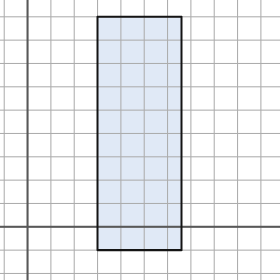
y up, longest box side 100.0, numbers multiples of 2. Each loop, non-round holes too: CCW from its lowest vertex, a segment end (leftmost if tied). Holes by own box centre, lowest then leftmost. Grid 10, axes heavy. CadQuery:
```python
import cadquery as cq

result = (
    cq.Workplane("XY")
    .moveTo(30.0, -10.0)
    .lineTo(66.0, -10.0)
    .lineTo(66.0, 90.0)
    .lineTo(30.0, 90.0)
    .close()
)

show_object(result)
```